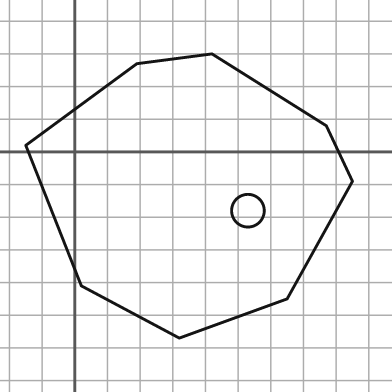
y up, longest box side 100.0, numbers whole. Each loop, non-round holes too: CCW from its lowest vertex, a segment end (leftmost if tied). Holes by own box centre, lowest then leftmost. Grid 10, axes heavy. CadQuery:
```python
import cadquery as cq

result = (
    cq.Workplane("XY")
    .moveTo(32.0, -57.0)
    .lineTo(65.0, -45.0)
    .lineTo(85.0, -9.0)
    .lineTo(77.0, 8.0)
    .lineTo(42.0, 30.0)
    .lineTo(19.0, 27.0)
    .lineTo(-15.0, 2.0)
    .lineTo(2.0, -41.0)
    .close()
    .moveTo(53.0, -18.0)
    .circle(5.0)
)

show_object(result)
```